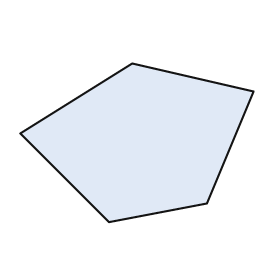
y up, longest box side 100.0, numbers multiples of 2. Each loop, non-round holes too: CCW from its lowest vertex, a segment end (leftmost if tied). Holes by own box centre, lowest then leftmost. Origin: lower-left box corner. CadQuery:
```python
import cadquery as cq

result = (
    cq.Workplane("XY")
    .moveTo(38.0, 0.0)
    .lineTo(80.0, 8.0)
    .lineTo(100.0, 56.0)
    .lineTo(48.0, 68.0)
    .lineTo(0.0, 38.0)
    .close()
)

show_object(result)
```